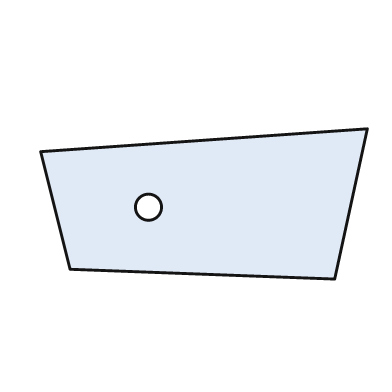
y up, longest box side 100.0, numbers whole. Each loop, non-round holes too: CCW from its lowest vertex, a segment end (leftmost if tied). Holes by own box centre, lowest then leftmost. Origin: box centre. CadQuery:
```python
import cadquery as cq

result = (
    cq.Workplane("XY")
    .moveTo(40.0, -23.0)
    .lineTo(50.0, 23.0)
    .lineTo(-50.0, 16.0)
    .lineTo(-41.0, -20.0)
    .close()
    .moveTo(-17.0, -1.0)
    .circle(4.0)
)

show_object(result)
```